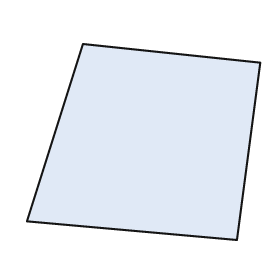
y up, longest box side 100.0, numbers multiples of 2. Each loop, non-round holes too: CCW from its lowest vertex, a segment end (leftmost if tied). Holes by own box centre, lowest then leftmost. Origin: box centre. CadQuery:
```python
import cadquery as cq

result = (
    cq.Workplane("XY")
    .moveTo(40.0, -42.0)
    .lineTo(50.0, 34.0)
    .lineTo(-26.0, 42.0)
    .lineTo(-50.0, -34.0)
    .close()
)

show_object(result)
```